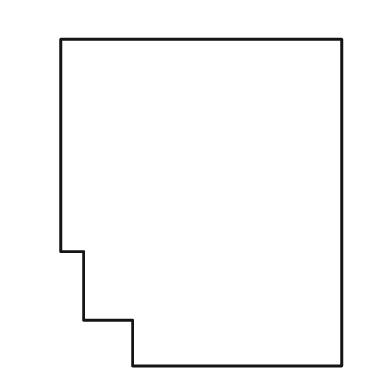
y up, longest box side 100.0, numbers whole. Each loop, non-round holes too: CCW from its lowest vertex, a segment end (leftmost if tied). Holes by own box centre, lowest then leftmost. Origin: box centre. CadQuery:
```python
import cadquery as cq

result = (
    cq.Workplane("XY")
    .moveTo(-21.0, -50.0)
    .lineTo(43.0, -50.0)
    .lineTo(43.0, 50.0)
    .lineTo(-43.0, 50.0)
    .lineTo(-43.0, -15.0)
    .lineTo(-36.0, -15.0)
    .lineTo(-36.0, -36.0)
    .lineTo(-21.0, -36.0)
    .close()
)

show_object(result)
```